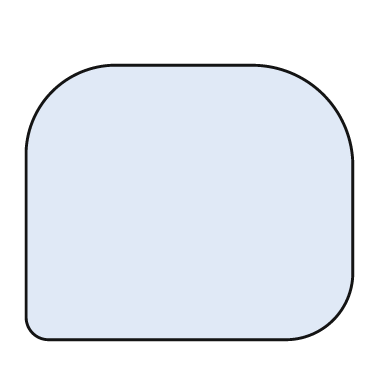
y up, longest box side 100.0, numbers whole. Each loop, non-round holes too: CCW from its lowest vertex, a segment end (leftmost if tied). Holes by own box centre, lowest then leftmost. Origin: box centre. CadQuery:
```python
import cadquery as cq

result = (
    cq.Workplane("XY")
    .moveTo(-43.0, -42.0)
    .lineTo(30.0, -42.0)
    .threePointArc((44.0, -36.0), (50.0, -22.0))
    .lineTo(50.0, 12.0)
    .threePointArc((41.0, 33.0), (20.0, 42.0))
    .lineTo(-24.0, 42.0)
    .threePointArc((-42.0, 34.0), (-50.0, 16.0))
    .lineTo(-50.0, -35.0)
    .threePointArc((-48.0, -40.0), (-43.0, -42.0))
    .close()
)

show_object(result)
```